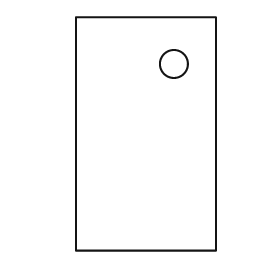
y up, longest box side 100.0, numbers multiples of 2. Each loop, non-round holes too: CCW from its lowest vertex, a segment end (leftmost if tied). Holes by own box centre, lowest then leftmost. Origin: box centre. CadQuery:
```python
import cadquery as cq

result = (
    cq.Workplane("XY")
    .moveTo(-30.0, -50.0)
    .lineTo(30.0, -50.0)
    .lineTo(30.0, 50.0)
    .lineTo(-30.0, 50.0)
    .close()
    .moveTo(12.0, 30.0)
    .circle(6.0)
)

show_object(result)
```